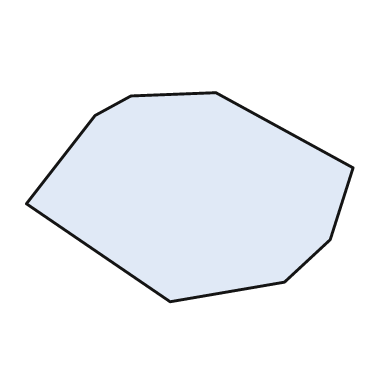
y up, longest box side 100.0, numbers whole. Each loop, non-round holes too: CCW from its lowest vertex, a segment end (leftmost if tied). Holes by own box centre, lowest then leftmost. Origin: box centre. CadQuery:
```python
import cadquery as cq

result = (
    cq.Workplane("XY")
    .moveTo(-6.0, -32.0)
    .lineTo(29.0, -26.0)
    .lineTo(43.0, -13.0)
    .lineTo(50.0, 9.0)
    .lineTo(8.0, 32.0)
    .lineTo(-18.0, 31.0)
    .lineTo(-29.0, 25.0)
    .lineTo(-50.0, -2.0)
    .close()
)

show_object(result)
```